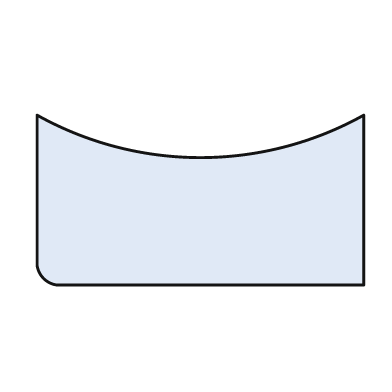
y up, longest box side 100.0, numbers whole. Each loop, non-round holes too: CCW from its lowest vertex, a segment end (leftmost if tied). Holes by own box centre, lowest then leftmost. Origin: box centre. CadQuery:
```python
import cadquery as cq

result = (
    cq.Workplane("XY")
    .moveTo(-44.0, -26.0)
    .lineTo(50.0, -26.0)
    .lineTo(50.0, 26.0)
    .threePointArc((0.0, 13.0), (-50.0, 26.0))
    .lineTo(-50.0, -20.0)
    .threePointArc((-48.0, -24.0), (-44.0, -26.0))
    .close()
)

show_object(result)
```